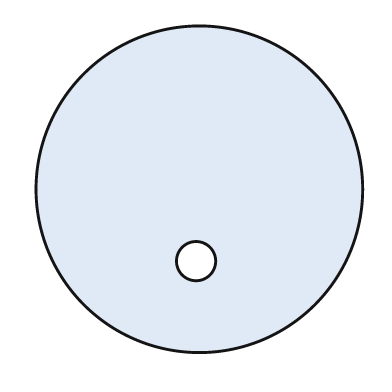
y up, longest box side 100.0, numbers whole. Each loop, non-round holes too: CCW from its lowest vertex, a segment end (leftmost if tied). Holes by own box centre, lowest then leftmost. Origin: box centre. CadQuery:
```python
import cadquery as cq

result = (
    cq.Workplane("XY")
    .moveTo(0.0, 0.0)
    .circle(50.0)
    .moveTo(-1.0, -22.0)
    .circle(6.0)
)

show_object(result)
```